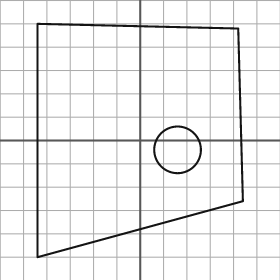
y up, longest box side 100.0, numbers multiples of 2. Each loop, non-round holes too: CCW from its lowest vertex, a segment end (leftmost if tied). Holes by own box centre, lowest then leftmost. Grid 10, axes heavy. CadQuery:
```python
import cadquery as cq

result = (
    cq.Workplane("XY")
    .moveTo(-44.0, -50.0)
    .lineTo(44.0, -26.0)
    .lineTo(42.0, 48.0)
    .lineTo(-44.0, 50.0)
    .close()
    .moveTo(16.0, -4.0)
    .circle(10.0)
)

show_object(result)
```